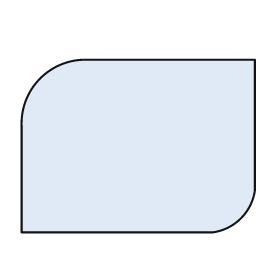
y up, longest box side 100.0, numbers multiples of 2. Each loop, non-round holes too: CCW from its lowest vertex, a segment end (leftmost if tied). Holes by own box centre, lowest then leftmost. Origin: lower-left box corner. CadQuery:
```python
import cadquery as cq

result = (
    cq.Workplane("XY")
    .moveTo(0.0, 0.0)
    .lineTo(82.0, 0.0)
    .threePointArc((94.0, 6.0), (100.0, 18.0))
    .lineTo(100.0, 74.0)
    .lineTo(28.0, 74.0)
    .threePointArc((8.0, 66.0), (0.0, 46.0))
    .close()
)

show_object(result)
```